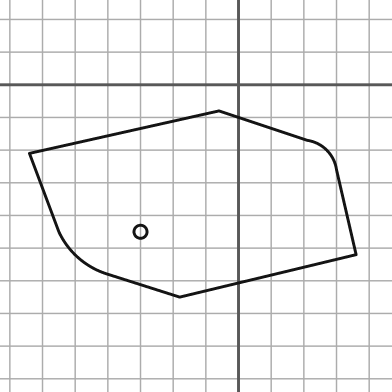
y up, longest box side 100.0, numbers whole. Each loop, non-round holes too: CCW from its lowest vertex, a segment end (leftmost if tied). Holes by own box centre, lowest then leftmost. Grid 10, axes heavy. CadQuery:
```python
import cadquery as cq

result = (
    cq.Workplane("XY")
    .moveTo(-18.0, -65.0)
    .lineTo(36.0, -52.0)
    .lineTo(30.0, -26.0)
    .threePointArc((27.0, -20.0), (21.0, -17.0))
    .lineTo(-6.0, -8.0)
    .lineTo(-64.0, -21.0)
    .lineTo(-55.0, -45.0)
    .threePointArc((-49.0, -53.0), (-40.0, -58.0))
    .close()
    .moveTo(-30.0, -45.0)
    .circle(2.0)
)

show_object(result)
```